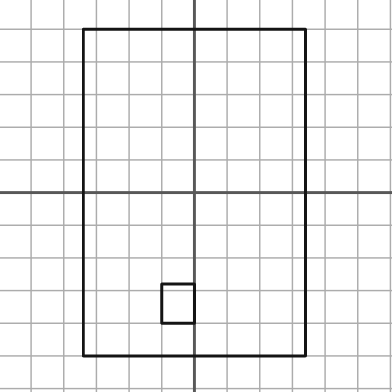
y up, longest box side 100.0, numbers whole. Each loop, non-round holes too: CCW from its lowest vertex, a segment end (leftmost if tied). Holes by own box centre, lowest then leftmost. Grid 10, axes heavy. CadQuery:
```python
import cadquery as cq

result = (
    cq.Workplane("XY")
    .moveTo(-34.0, -50.0)
    .lineTo(34.0, -50.0)
    .lineTo(34.0, 50.0)
    .lineTo(-34.0, 50.0)
    .close()
    .moveTo(-10.0, -40.0)
    .lineTo(0.0, -40.0)
    .lineTo(0.0, -28.0)
    .lineTo(-10.0, -28.0)
    .close()
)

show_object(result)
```